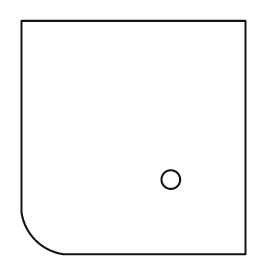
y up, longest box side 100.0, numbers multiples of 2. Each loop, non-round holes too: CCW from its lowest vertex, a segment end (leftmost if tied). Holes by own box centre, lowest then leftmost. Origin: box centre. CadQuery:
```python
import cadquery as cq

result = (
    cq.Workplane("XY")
    .moveTo(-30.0, -50.0)
    .lineTo(48.0, -50.0)
    .lineTo(48.0, 50.0)
    .lineTo(-48.0, 50.0)
    .lineTo(-48.0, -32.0)
    .threePointArc((-42.0, -44.0), (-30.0, -50.0))
    .close()
    .moveTo(16.0, -18.0)
    .circle(4.0)
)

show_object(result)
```